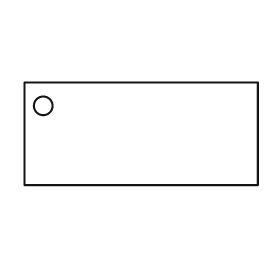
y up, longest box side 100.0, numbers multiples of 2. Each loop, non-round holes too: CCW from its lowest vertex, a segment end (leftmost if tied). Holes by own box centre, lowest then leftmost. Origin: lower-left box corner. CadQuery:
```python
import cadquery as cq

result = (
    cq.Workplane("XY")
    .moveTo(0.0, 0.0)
    .lineTo(100.0, 0.0)
    .lineTo(100.0, 44.0)
    .lineTo(0.0, 44.0)
    .close()
    .moveTo(8.0, 34.0)
    .circle(4.0)
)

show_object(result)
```